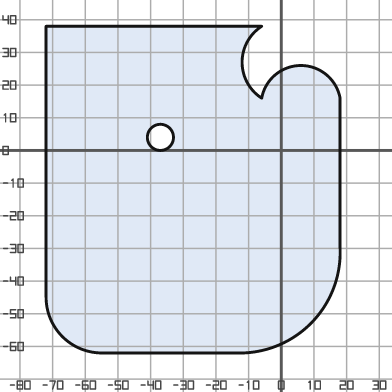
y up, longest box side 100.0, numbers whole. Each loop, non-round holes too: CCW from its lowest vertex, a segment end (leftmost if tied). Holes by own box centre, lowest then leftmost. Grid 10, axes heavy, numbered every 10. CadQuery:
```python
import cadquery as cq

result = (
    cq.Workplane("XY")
    .moveTo(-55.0, -62.0)
    .lineTo(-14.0, -62.0)
    .threePointArc((9.0, -53.0), (18.0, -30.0))
    .lineTo(18.0, 16.0)
    .threePointArc((6.0, 26.0), (-6.0, 16.0))
    .threePointArc((-12.0, 27.0), (-6.0, 38.0))
    .lineTo(-72.0, 38.0)
    .lineTo(-72.0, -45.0)
    .threePointArc((-67.0, -57.0), (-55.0, -62.0))
    .close()
    .moveTo(-37.0, 4.0)
    .circle(4.0)
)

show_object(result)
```